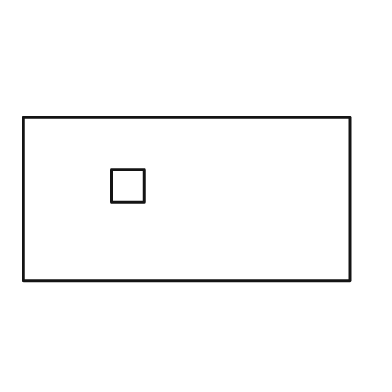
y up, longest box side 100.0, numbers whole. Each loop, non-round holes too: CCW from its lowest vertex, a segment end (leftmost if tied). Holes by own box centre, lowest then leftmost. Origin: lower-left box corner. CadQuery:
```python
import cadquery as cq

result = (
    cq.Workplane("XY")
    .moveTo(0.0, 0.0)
    .lineTo(100.0, 0.0)
    .lineTo(100.0, 50.0)
    .lineTo(0.0, 50.0)
    .close()
    .moveTo(27.0, 24.0)
    .lineTo(37.0, 24.0)
    .lineTo(37.0, 34.0)
    .lineTo(27.0, 34.0)
    .close()
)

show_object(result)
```